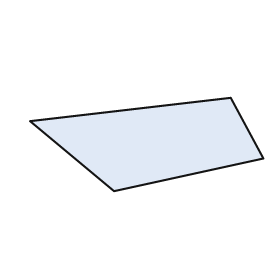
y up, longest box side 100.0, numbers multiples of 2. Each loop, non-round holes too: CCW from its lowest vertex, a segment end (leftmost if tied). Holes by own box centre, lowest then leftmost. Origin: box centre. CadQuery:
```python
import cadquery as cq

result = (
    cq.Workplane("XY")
    .moveTo(-14.0, -20.0)
    .lineTo(50.0, -6.0)
    .lineTo(36.0, 20.0)
    .lineTo(-50.0, 10.0)
    .close()
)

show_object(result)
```